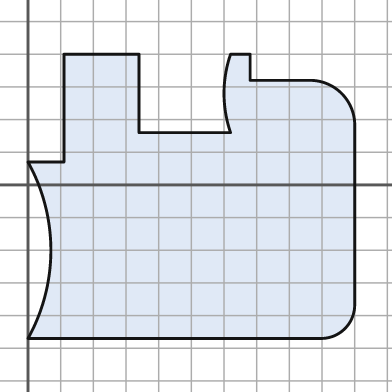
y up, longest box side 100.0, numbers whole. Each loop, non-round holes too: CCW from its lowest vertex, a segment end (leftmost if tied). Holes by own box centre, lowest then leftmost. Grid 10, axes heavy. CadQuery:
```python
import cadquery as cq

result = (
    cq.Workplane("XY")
    .moveTo(0.0, -47.0)
    .lineTo(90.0, -47.0)
    .threePointArc((97.0, -44.0), (100.0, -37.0))
    .lineTo(100.0, 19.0)
    .threePointArc((96.0, 28.0), (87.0, 32.0))
    .lineTo(68.0, 32.0)
    .lineTo(68.0, 40.0)
    .lineTo(62.0, 40.0)
    .threePointArc((60.0, 28.0), (62.0, 16.0))
    .lineTo(34.0, 16.0)
    .lineTo(34.0, 40.0)
    .lineTo(11.0, 40.0)
    .lineTo(11.0, 7.0)
    .lineTo(0.0, 7.0)
    .threePointArc((7.0, -20.0), (0.0, -47.0))
    .close()
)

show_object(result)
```